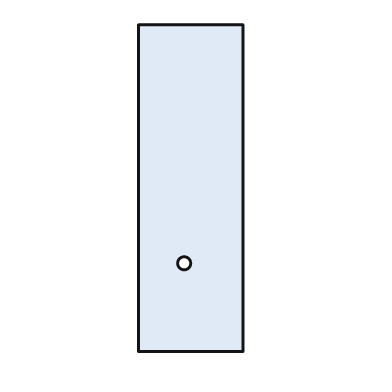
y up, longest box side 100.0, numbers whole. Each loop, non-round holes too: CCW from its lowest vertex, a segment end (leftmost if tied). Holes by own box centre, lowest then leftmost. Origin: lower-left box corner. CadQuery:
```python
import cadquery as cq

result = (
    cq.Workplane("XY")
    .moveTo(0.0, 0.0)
    .lineTo(32.0, 0.0)
    .lineTo(32.0, 100.0)
    .lineTo(0.0, 100.0)
    .close()
    .moveTo(14.0, 27.0)
    .circle(2.0)
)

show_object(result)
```